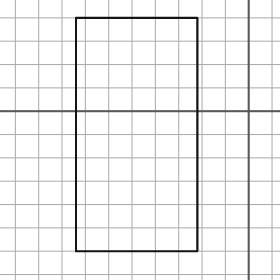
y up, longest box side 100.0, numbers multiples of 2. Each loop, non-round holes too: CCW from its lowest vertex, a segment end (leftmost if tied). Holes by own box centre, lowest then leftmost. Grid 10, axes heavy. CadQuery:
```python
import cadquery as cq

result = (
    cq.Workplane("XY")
    .moveTo(-74.0, -60.0)
    .lineTo(-22.0, -60.0)
    .lineTo(-22.0, 40.0)
    .lineTo(-74.0, 40.0)
    .close()
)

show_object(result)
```